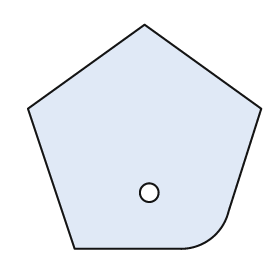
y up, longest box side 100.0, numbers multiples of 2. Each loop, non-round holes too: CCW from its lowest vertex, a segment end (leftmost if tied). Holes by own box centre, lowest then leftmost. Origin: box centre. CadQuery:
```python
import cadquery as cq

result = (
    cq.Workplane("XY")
    .moveTo(-30.0, -48.0)
    .lineTo(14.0, -48.0)
    .threePointArc((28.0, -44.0), (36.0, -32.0))
    .lineTo(50.0, 12.0)
    .lineTo(0.0, 48.0)
    .lineTo(-50.0, 12.0)
    .close()
    .moveTo(2.0, -24.0)
    .circle(4.0)
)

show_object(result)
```